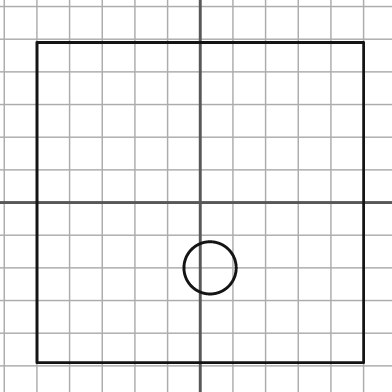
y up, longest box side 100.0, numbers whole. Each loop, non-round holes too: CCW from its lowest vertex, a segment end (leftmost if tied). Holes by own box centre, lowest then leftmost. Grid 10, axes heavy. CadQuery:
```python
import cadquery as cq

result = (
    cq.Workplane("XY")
    .moveTo(-50.0, -49.0)
    .lineTo(50.0, -49.0)
    .lineTo(50.0, 49.0)
    .lineTo(-50.0, 49.0)
    .close()
    .moveTo(3.0, -20.0)
    .circle(8.0)
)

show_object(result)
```